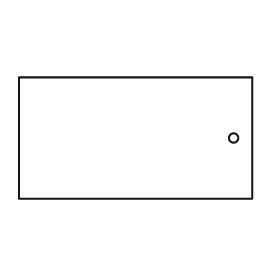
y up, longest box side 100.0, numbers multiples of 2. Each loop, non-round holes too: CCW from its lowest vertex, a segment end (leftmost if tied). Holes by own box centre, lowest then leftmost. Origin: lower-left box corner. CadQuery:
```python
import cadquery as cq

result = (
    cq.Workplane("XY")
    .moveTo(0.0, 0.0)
    .lineTo(100.0, 0.0)
    .lineTo(100.0, 52.0)
    .lineTo(0.0, 52.0)
    .close()
    .moveTo(92.0, 26.0)
    .circle(2.0)
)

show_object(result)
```